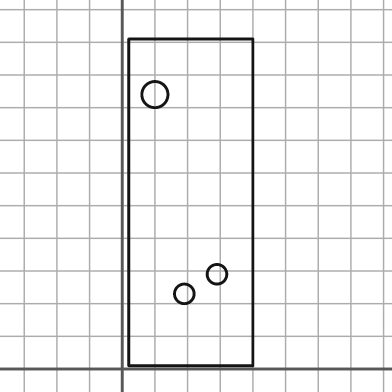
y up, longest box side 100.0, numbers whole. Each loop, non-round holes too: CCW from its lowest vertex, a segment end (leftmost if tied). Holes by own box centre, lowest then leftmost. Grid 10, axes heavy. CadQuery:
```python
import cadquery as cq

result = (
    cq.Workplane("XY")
    .moveTo(2.0, 1.0)
    .lineTo(40.0, 1.0)
    .lineTo(40.0, 101.0)
    .lineTo(2.0, 101.0)
    .close()
    .moveTo(19.0, 23.0)
    .circle(3.0)
    .moveTo(29.0, 29.0)
    .circle(3.0)
    .moveTo(10.0, 84.0)
    .circle(4.0)
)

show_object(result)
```